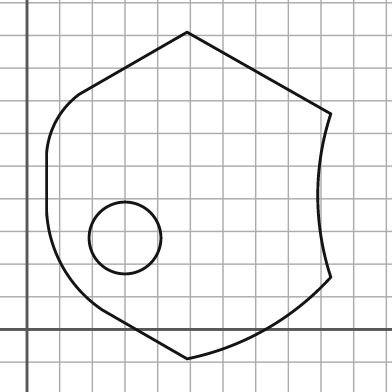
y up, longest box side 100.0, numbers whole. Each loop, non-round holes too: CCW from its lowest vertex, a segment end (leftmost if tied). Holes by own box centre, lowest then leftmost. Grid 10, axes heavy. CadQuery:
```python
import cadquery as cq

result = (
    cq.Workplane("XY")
    .moveTo(49.0, -9.0)
    .threePointArc((73.0, 0.0), (93.0, 16.0))
    .threePointArc((89.0, 41.0), (93.0, 66.0))
    .lineTo(49.0, 91.0)
    .lineTo(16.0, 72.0)
    .threePointArc((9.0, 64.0), (6.0, 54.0))
    .lineTo(6.0, 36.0)
    .threePointArc((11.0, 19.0), (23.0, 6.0))
    .close()
    .moveTo(30.0, 28.0)
    .circle(11.0)
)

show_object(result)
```